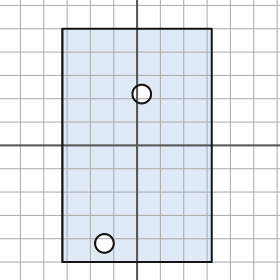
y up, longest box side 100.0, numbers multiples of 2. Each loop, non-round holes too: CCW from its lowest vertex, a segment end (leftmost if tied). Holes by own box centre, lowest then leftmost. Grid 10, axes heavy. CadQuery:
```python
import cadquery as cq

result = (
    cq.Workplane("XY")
    .moveTo(-32.0, -50.0)
    .lineTo(32.0, -50.0)
    .lineTo(32.0, 50.0)
    .lineTo(-32.0, 50.0)
    .close()
    .moveTo(-14.0, -42.0)
    .circle(4.0)
    .moveTo(2.0, 22.0)
    .circle(4.0)
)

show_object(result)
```